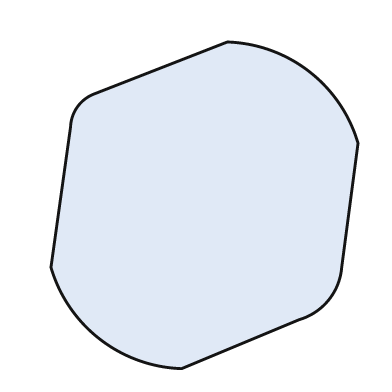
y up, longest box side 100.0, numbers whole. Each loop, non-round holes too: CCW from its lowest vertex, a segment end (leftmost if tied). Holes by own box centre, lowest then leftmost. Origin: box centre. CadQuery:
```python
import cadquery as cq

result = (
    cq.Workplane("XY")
    .moveTo(-7.0, -50.0)
    .lineTo(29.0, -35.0)
    .threePointArc((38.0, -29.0), (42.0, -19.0))
    .lineTo(47.0, 19.0)
    .threePointArc((32.0, 41.0), (7.0, 50.0))
    .lineTo(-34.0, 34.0)
    .threePointArc((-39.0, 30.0), (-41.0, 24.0))
    .lineTo(-47.0, -19.0)
    .threePointArc((-32.0, -41.0), (-7.0, -50.0))
    .close()
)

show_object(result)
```